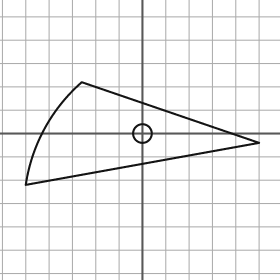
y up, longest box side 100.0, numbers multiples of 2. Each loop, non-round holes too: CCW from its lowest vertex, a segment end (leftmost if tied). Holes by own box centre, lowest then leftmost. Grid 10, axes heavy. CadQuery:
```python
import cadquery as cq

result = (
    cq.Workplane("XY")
    .moveTo(-50.0, -22.0)
    .lineTo(50.0, -4.0)
    .lineTo(-26.0, 22.0)
    .threePointArc((-42.0, 2.0), (-50.0, -22.0))
    .close()
    .moveTo(0.0, 0.0)
    .circle(4.0)
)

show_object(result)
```